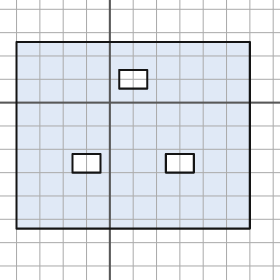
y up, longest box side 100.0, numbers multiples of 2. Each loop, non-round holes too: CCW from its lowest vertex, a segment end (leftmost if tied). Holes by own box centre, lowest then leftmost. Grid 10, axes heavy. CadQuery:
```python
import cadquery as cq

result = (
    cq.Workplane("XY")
    .moveTo(-40.0, -54.0)
    .lineTo(60.0, -54.0)
    .lineTo(60.0, 26.0)
    .lineTo(-40.0, 26.0)
    .close()
    .moveTo(-16.0, -30.0)
    .lineTo(-4.0, -30.0)
    .lineTo(-4.0, -22.0)
    .lineTo(-16.0, -22.0)
    .close()
    .moveTo(24.0, -30.0)
    .lineTo(36.0, -30.0)
    .lineTo(36.0, -22.0)
    .lineTo(24.0, -22.0)
    .close()
    .moveTo(4.0, 6.0)
    .lineTo(16.0, 6.0)
    .lineTo(16.0, 14.0)
    .lineTo(4.0, 14.0)
    .close()
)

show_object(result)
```